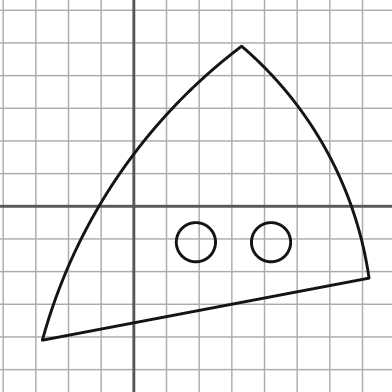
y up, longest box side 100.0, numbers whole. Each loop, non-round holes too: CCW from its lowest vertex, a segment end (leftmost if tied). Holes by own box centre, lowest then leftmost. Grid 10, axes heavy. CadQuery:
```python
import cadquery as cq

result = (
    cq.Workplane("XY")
    .moveTo(-28.0, -41.0)
    .lineTo(72.0, -22.0)
    .threePointArc((59.0, 17.0), (33.0, 49.0))
    .threePointArc((-5.0, 9.0), (-28.0, -41.0))
    .close()
    .moveTo(19.0, -11.0)
    .circle(6.0)
    .moveTo(42.0, -11.0)
    .circle(6.0)
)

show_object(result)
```